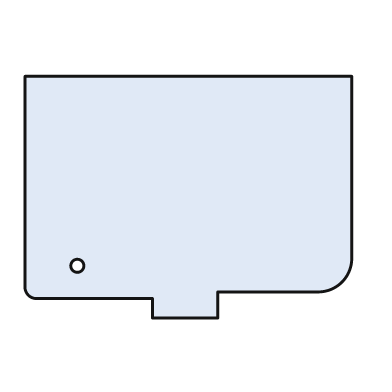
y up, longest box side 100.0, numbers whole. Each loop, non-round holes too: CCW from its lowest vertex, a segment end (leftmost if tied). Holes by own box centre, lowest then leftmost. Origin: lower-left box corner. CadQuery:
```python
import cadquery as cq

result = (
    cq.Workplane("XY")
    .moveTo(39.0, 0.0)
    .lineTo(59.0, 0.0)
    .lineTo(59.0, 8.0)
    .lineTo(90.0, 8.0)
    .threePointArc((97.0, 11.0), (100.0, 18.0))
    .lineTo(100.0, 74.0)
    .lineTo(0.0, 74.0)
    .lineTo(0.0, 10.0)
    .threePointArc((1.0, 7.0), (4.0, 6.0))
    .lineTo(39.0, 6.0)
    .close()
    .moveTo(16.0, 16.0)
    .circle(2.0)
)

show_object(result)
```